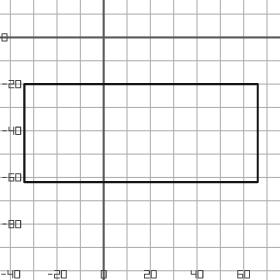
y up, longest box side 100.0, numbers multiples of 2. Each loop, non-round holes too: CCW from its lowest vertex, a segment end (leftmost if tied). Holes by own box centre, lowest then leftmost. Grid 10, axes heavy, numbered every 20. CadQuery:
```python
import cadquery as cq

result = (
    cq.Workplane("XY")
    .moveTo(-34.0, -62.0)
    .lineTo(66.0, -62.0)
    .lineTo(66.0, -20.0)
    .lineTo(-34.0, -20.0)
    .close()
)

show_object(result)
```